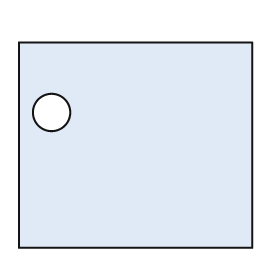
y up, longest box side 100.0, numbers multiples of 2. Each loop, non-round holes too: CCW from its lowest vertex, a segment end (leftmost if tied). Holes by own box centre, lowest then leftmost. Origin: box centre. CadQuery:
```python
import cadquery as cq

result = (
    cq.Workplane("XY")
    .moveTo(-50.0, -44.0)
    .lineTo(50.0, -44.0)
    .lineTo(50.0, 44.0)
    .lineTo(-50.0, 44.0)
    .close()
    .moveTo(-36.0, 14.0)
    .circle(8.0)
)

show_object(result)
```